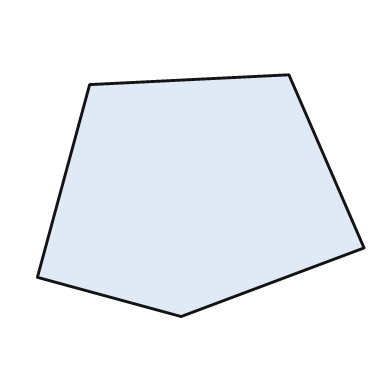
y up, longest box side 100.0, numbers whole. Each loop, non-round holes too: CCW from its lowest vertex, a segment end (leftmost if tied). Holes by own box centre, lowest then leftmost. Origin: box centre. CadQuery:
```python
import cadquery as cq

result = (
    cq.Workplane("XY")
    .moveTo(-6.0, -37.0)
    .lineTo(50.0, -16.0)
    .lineTo(27.0, 37.0)
    .lineTo(-34.0, 34.0)
    .lineTo(-50.0, -25.0)
    .close()
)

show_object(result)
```